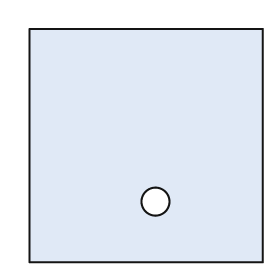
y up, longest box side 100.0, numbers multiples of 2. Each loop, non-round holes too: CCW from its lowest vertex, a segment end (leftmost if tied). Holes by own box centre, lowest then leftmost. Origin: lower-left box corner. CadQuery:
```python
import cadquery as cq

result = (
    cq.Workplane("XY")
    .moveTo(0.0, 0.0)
    .lineTo(100.0, 0.0)
    .lineTo(100.0, 100.0)
    .lineTo(0.0, 100.0)
    .close()
    .moveTo(54.0, 26.0)
    .circle(6.0)
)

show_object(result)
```